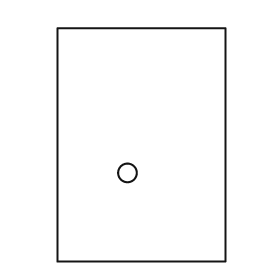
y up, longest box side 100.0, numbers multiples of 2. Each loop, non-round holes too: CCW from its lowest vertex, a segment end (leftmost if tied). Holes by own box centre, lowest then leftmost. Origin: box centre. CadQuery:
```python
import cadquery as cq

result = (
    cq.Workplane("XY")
    .moveTo(-36.0, -50.0)
    .lineTo(36.0, -50.0)
    .lineTo(36.0, 50.0)
    .lineTo(-36.0, 50.0)
    .close()
    .moveTo(-6.0, -12.0)
    .circle(4.0)
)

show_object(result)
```